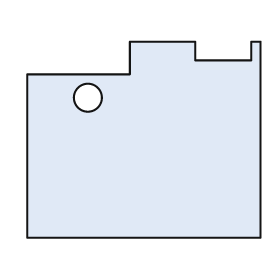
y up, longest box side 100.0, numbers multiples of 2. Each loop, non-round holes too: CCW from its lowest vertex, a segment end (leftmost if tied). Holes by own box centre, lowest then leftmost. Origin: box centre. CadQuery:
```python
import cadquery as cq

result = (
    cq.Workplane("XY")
    .moveTo(-50.0, -42.0)
    .lineTo(50.0, -42.0)
    .lineTo(50.0, 42.0)
    .lineTo(46.0, 42.0)
    .lineTo(46.0, 34.0)
    .lineTo(22.0, 34.0)
    .lineTo(22.0, 42.0)
    .lineTo(-6.0, 42.0)
    .lineTo(-6.0, 28.0)
    .lineTo(-50.0, 28.0)
    .close()
    .moveTo(-24.0, 18.0)
    .circle(6.0)
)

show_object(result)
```